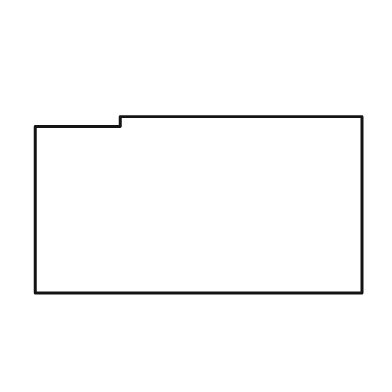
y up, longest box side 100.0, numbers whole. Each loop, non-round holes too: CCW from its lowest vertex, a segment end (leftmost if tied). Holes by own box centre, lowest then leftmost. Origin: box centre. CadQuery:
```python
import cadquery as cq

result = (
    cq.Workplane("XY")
    .moveTo(-50.0, -27.0)
    .lineTo(50.0, -27.0)
    .lineTo(50.0, 27.0)
    .lineTo(-24.0, 27.0)
    .lineTo(-24.0, 24.0)
    .lineTo(-50.0, 24.0)
    .close()
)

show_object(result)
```